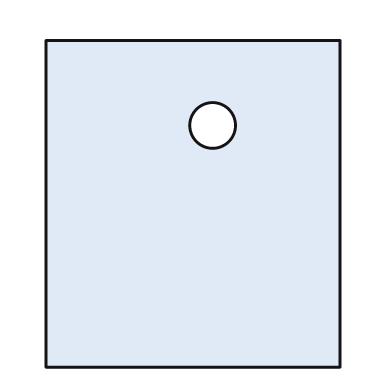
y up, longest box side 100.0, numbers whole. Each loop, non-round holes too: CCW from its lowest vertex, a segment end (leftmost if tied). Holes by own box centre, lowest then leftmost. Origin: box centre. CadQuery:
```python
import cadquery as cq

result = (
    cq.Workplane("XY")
    .moveTo(-45.0, -50.0)
    .lineTo(45.0, -50.0)
    .lineTo(45.0, 50.0)
    .lineTo(-45.0, 50.0)
    .close()
    .moveTo(6.0, 24.0)
    .circle(7.0)
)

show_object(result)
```